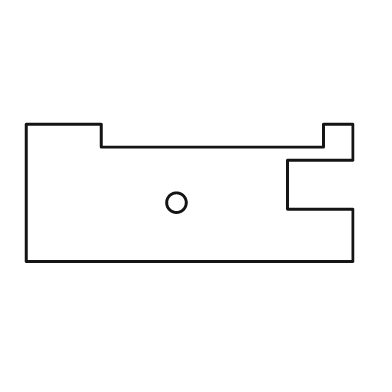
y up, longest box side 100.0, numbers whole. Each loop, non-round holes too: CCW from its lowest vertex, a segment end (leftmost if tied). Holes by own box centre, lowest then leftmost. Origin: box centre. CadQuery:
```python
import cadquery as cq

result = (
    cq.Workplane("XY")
    .moveTo(-50.0, -21.0)
    .lineTo(50.0, -21.0)
    .lineTo(50.0, -5.0)
    .lineTo(30.0, -5.0)
    .lineTo(30.0, 10.0)
    .lineTo(50.0, 10.0)
    .lineTo(50.0, 21.0)
    .lineTo(41.0, 21.0)
    .lineTo(41.0, 14.0)
    .lineTo(-27.0, 14.0)
    .lineTo(-27.0, 21.0)
    .lineTo(-50.0, 21.0)
    .close()
    .moveTo(-4.0, -3.0)
    .circle(3.0)
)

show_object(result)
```